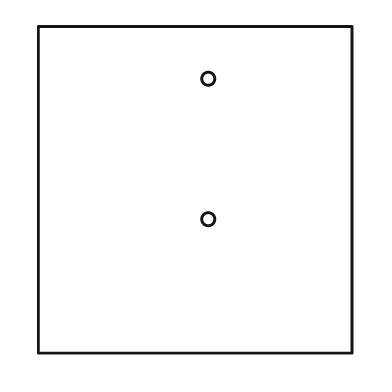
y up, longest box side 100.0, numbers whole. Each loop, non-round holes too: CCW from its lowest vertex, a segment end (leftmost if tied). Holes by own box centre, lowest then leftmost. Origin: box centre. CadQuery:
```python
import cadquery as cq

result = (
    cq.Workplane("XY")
    .moveTo(-48.0, -50.0)
    .lineTo(48.0, -50.0)
    .lineTo(48.0, 50.0)
    .lineTo(-48.0, 50.0)
    .close()
    .moveTo(4.0, -9.0)
    .circle(2.0)
    .moveTo(4.0, 34.0)
    .circle(2.0)
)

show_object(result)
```